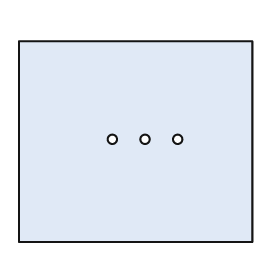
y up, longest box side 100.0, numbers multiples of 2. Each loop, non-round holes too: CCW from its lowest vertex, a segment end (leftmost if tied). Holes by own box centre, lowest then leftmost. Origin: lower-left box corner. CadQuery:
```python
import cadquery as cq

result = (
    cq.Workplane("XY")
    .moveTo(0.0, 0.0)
    .lineTo(100.0, 0.0)
    .lineTo(100.0, 86.0)
    .lineTo(0.0, 86.0)
    .close()
    .moveTo(40.0, 44.0)
    .circle(2.0)
    .moveTo(54.0, 44.0)
    .circle(2.0)
    .moveTo(68.0, 44.0)
    .circle(2.0)
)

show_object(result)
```